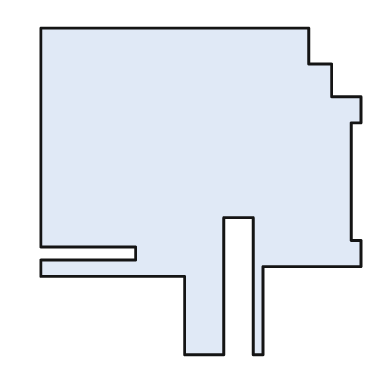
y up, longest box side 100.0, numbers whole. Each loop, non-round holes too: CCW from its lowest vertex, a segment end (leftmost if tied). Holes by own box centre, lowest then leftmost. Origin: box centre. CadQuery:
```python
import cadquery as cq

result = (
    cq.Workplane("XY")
    .moveTo(-5.0, -50.0)
    .lineTo(7.0, -50.0)
    .lineTo(7.0, -8.0)
    .lineTo(16.0, -8.0)
    .lineTo(16.0, -50.0)
    .lineTo(19.0, -50.0)
    .lineTo(19.0, -23.0)
    .lineTo(49.0, -23.0)
    .lineTo(49.0, -15.0)
    .lineTo(46.0, -15.0)
    .lineTo(46.0, 21.0)
    .lineTo(49.0, 21.0)
    .lineTo(49.0, 29.0)
    .lineTo(40.0, 29.0)
    .lineTo(40.0, 39.0)
    .lineTo(33.0, 39.0)
    .lineTo(33.0, 50.0)
    .lineTo(-49.0, 50.0)
    .lineTo(-49.0, -17.0)
    .lineTo(-20.0, -17.0)
    .lineTo(-20.0, -21.0)
    .lineTo(-49.0, -21.0)
    .lineTo(-49.0, -26.0)
    .lineTo(-5.0, -26.0)
    .close()
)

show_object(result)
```